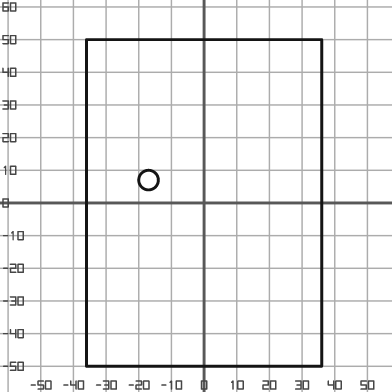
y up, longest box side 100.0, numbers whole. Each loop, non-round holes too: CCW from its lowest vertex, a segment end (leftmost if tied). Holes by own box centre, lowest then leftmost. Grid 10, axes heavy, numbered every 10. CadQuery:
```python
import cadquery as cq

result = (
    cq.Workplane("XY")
    .moveTo(-36.0, -50.0)
    .lineTo(36.0, -50.0)
    .lineTo(36.0, 50.0)
    .lineTo(-36.0, 50.0)
    .close()
    .moveTo(-17.0, 7.0)
    .circle(3.0)
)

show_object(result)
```